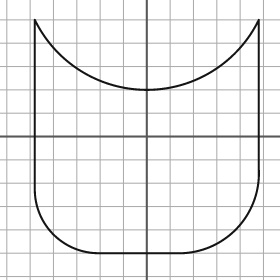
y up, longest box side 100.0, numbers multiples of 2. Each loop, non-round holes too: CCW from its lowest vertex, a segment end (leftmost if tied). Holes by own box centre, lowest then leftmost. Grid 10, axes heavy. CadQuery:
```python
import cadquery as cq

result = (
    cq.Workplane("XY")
    .moveTo(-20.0, -50.0)
    .lineTo(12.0, -50.0)
    .threePointArc((38.0, -40.0), (48.0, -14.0))
    .lineTo(48.0, 50.0)
    .threePointArc((0.0, 20.0), (-48.0, 50.0))
    .lineTo(-48.0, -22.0)
    .threePointArc((-40.0, -42.0), (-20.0, -50.0))
    .close()
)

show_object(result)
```